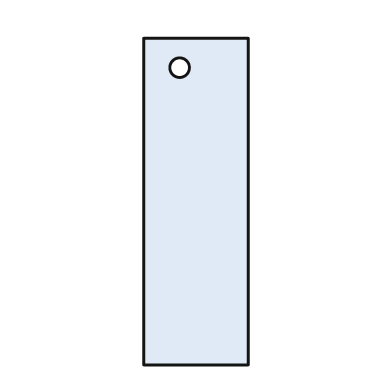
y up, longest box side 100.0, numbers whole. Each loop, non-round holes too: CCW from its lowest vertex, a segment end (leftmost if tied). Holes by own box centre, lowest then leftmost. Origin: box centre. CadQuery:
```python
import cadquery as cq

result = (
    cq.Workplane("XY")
    .moveTo(-16.0, -50.0)
    .lineTo(16.0, -50.0)
    .lineTo(16.0, 50.0)
    .lineTo(-16.0, 50.0)
    .close()
    .moveTo(-5.0, 41.0)
    .circle(3.0)
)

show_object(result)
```